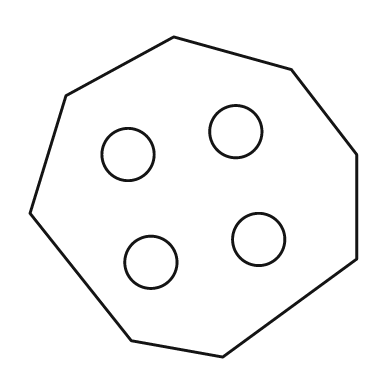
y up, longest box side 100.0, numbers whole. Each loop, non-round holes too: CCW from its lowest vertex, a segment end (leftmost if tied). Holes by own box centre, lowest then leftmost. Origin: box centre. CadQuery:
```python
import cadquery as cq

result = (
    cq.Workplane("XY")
    .moveTo(9.0, -49.0)
    .lineTo(50.0, -19.0)
    .lineTo(50.0, 13.0)
    .lineTo(30.0, 39.0)
    .lineTo(-6.0, 49.0)
    .lineTo(-39.0, 31.0)
    .lineTo(-50.0, -5.0)
    .lineTo(-19.0, -44.0)
    .close()
    .moveTo(-13.0, -20.0)
    .circle(8.0)
    .moveTo(20.0, -13.0)
    .circle(8.0)
    .moveTo(-20.0, 13.0)
    .circle(8.0)
    .moveTo(13.0, 20.0)
    .circle(8.0)
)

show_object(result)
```